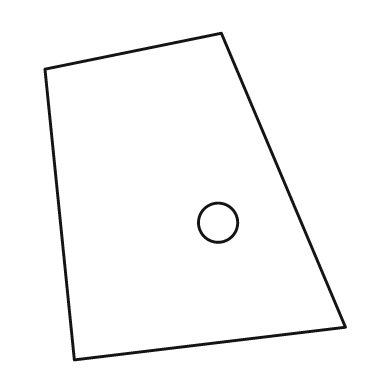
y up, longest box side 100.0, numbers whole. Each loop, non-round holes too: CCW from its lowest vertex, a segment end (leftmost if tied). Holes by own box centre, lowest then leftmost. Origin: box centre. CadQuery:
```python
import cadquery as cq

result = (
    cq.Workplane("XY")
    .moveTo(-37.0, -50.0)
    .lineTo(46.0, -40.0)
    .lineTo(8.0, 50.0)
    .lineTo(-46.0, 39.0)
    .close()
    .moveTo(7.0, -8.0)
    .circle(6.0)
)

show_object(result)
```